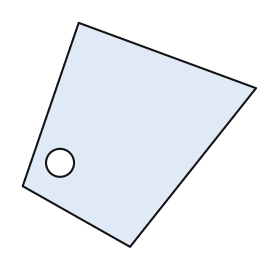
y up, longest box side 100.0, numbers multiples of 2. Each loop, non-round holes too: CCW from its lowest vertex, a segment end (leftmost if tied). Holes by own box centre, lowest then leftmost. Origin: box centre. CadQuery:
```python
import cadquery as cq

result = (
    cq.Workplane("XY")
    .moveTo(-4.0, -48.0)
    .lineTo(50.0, 20.0)
    .lineTo(-26.0, 48.0)
    .lineTo(-50.0, -22.0)
    .close()
    .moveTo(-34.0, -12.0)
    .circle(6.0)
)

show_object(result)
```